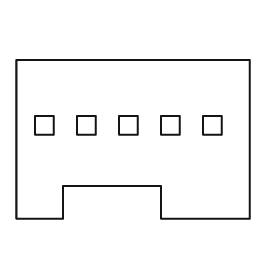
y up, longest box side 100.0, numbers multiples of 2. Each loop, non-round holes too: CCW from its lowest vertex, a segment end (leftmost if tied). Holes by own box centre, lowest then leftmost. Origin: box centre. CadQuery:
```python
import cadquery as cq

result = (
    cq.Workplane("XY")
    .moveTo(-50.0, -34.0)
    .lineTo(-30.0, -34.0)
    .lineTo(-30.0, -20.0)
    .lineTo(12.0, -20.0)
    .lineTo(12.0, -34.0)
    .lineTo(50.0, -34.0)
    .lineTo(50.0, 34.0)
    .lineTo(-50.0, 34.0)
    .close()
    .moveTo(-42.0, 2.0)
    .lineTo(-34.0, 2.0)
    .lineTo(-34.0, 10.0)
    .lineTo(-42.0, 10.0)
    .close()
    .moveTo(-24.0, 2.0)
    .lineTo(-16.0, 2.0)
    .lineTo(-16.0, 10.0)
    .lineTo(-24.0, 10.0)
    .close()
    .moveTo(-6.0, 2.0)
    .lineTo(2.0, 2.0)
    .lineTo(2.0, 10.0)
    .lineTo(-6.0, 10.0)
    .close()
    .moveTo(12.0, 2.0)
    .lineTo(20.0, 2.0)
    .lineTo(20.0, 10.0)
    .lineTo(12.0, 10.0)
    .close()
    .moveTo(30.0, 2.0)
    .lineTo(38.0, 2.0)
    .lineTo(38.0, 10.0)
    .lineTo(30.0, 10.0)
    .close()
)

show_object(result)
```